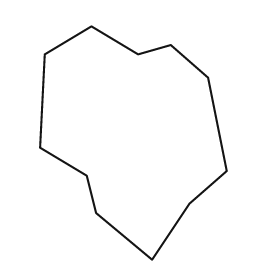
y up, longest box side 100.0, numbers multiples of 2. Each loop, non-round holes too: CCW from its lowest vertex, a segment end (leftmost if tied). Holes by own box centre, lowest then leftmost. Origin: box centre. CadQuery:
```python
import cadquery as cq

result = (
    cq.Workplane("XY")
    .moveTo(8.0, -50.0)
    .lineTo(24.0, -26.0)
    .lineTo(40.0, -12.0)
    .lineTo(32.0, 28.0)
    .lineTo(16.0, 42.0)
    .lineTo(2.0, 38.0)
    .lineTo(-18.0, 50.0)
    .lineTo(-38.0, 38.0)
    .lineTo(-40.0, -2.0)
    .lineTo(-20.0, -14.0)
    .lineTo(-16.0, -30.0)
    .close()
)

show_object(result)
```